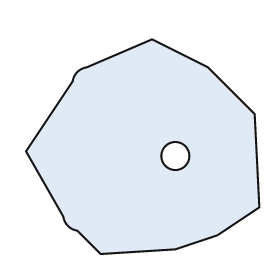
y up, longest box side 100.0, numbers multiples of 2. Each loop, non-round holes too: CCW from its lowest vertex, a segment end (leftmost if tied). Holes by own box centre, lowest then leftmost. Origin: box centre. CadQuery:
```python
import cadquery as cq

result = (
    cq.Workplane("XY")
    .moveTo(-18.0, -46.0)
    .lineTo(14.0, -44.0)
    .lineTo(32.0, -38.0)
    .lineTo(50.0, -26.0)
    .lineTo(48.0, 14.0)
    .lineTo(28.0, 34.0)
    .lineTo(4.0, 46.0)
    .lineTo(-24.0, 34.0)
    .threePointArc((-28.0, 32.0), (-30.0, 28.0))
    .lineTo(-50.0, -2.0)
    .lineTo(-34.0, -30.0)
    .threePointArc((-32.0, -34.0), (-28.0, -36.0))
    .close()
    .moveTo(14.0, -4.0)
    .circle(6.0)
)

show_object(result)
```